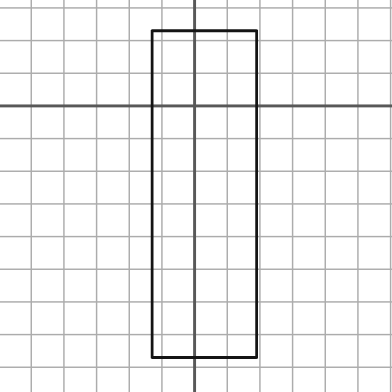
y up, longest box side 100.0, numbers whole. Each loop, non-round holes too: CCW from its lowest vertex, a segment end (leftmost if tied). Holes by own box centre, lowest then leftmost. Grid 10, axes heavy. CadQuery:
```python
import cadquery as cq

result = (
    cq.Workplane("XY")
    .moveTo(-13.0, -77.0)
    .lineTo(19.0, -77.0)
    .lineTo(19.0, 23.0)
    .lineTo(-13.0, 23.0)
    .close()
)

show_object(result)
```